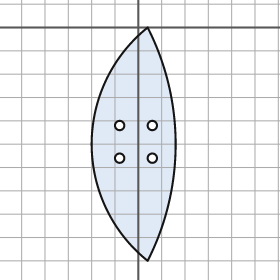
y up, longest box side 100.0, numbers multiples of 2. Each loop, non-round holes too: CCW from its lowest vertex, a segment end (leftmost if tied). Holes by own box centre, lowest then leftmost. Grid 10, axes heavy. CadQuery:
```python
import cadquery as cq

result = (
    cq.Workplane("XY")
    .moveTo(4.0, -100.0)
    .threePointArc((16.0, -50.0), (4.0, 0.0))
    .threePointArc((-20.0, -50.0), (4.0, -100.0))
    .close()
    .moveTo(-8.0, -56.0)
    .circle(2.0)
    .moveTo(6.0, -56.0)
    .circle(2.0)
    .moveTo(-8.0, -42.0)
    .circle(2.0)
    .moveTo(6.0, -42.0)
    .circle(2.0)
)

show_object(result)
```